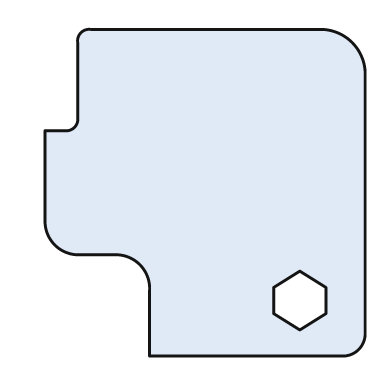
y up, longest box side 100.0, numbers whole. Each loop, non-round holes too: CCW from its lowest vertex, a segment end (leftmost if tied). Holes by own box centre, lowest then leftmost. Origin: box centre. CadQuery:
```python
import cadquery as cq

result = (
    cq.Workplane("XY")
    .moveTo(-17.0, -50.0)
    .lineTo(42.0, -50.0)
    .threePointArc((47.0, -48.0), (49.0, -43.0))
    .lineTo(49.0, 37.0)
    .threePointArc((45.0, 46.0), (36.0, 50.0))
    .lineTo(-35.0, 50.0)
    .threePointArc((-38.0, 49.0), (-39.0, 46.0))
    .lineTo(-39.0, 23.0)
    .threePointArc((-40.0, 20.0), (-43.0, 19.0))
    .lineTo(-49.0, 19.0)
    .lineTo(-49.0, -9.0)
    .threePointArc((-46.0, -16.0), (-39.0, -19.0))
    .lineTo(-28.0, -19.0)
    .threePointArc((-20.0, -22.0), (-17.0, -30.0))
    .close()
    .moveTo(29.0, -42.0)
    .lineTo(37.0, -37.0)
    .lineTo(37.0, -29.0)
    .lineTo(29.0, -24.0)
    .lineTo(21.0, -29.0)
    .lineTo(21.0, -37.0)
    .close()
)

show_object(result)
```